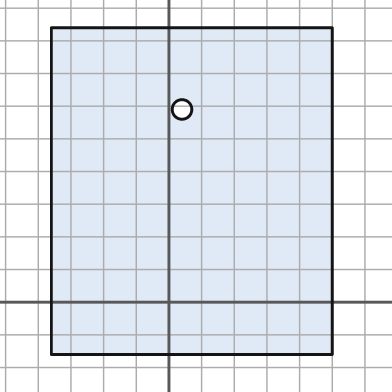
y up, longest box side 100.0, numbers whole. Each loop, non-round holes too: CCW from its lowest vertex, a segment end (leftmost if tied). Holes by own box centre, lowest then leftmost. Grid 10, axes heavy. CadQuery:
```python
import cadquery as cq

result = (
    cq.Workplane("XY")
    .moveTo(-36.0, -16.0)
    .lineTo(50.0, -16.0)
    .lineTo(50.0, 84.0)
    .lineTo(-36.0, 84.0)
    .close()
    .moveTo(4.0, 59.0)
    .circle(3.0)
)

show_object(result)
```